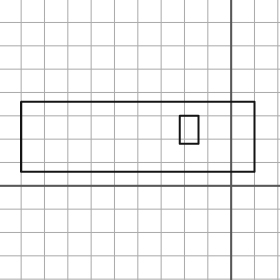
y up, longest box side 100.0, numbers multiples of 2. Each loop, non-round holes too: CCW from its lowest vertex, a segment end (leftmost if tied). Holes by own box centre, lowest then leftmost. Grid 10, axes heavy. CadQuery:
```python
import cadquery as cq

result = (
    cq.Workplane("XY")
    .moveTo(-90.0, 6.0)
    .lineTo(10.0, 6.0)
    .lineTo(10.0, 36.0)
    .lineTo(-90.0, 36.0)
    .close()
    .moveTo(-22.0, 18.0)
    .lineTo(-14.0, 18.0)
    .lineTo(-14.0, 30.0)
    .lineTo(-22.0, 30.0)
    .close()
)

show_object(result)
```